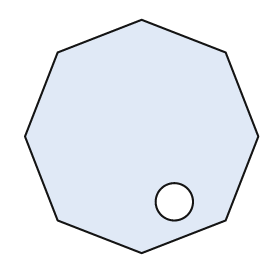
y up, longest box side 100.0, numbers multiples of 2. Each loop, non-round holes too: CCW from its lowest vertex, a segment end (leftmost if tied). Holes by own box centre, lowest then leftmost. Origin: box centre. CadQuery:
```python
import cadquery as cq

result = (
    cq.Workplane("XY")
    .moveTo(0.0, -50.0)
    .lineTo(36.0, -36.0)
    .lineTo(50.0, 0.0)
    .lineTo(36.0, 36.0)
    .lineTo(0.0, 50.0)
    .lineTo(-36.0, 36.0)
    .lineTo(-50.0, 0.0)
    .lineTo(-36.0, -36.0)
    .close()
    .moveTo(14.0, -28.0)
    .circle(8.0)
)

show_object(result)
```